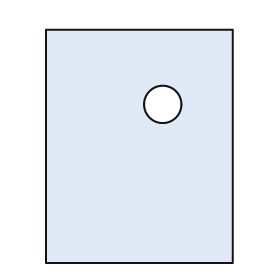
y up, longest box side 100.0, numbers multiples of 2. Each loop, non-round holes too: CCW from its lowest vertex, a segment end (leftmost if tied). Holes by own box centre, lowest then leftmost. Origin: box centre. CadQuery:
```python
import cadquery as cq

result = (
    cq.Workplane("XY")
    .moveTo(-40.0, -50.0)
    .lineTo(40.0, -50.0)
    .lineTo(40.0, 50.0)
    .lineTo(-40.0, 50.0)
    .close()
    .moveTo(10.0, 18.0)
    .circle(8.0)
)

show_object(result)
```